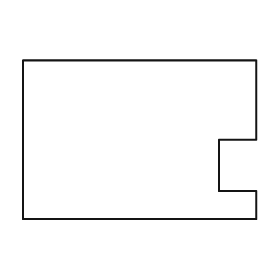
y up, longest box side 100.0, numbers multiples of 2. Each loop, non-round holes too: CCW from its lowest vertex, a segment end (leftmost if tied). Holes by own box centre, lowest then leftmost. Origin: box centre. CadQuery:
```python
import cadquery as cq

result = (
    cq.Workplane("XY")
    .moveTo(-50.0, -34.0)
    .lineTo(50.0, -34.0)
    .lineTo(50.0, -22.0)
    .lineTo(34.0, -22.0)
    .lineTo(34.0, 0.0)
    .lineTo(50.0, 0.0)
    .lineTo(50.0, 34.0)
    .lineTo(-50.0, 34.0)
    .close()
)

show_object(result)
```